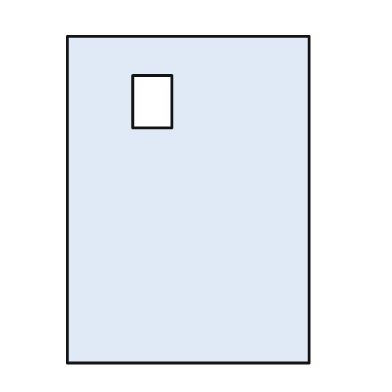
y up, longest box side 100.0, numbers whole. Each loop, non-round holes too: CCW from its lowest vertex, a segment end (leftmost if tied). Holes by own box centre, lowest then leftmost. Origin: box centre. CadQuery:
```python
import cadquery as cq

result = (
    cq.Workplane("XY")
    .moveTo(-37.0, -50.0)
    .lineTo(37.0, -50.0)
    .lineTo(37.0, 50.0)
    .lineTo(-37.0, 50.0)
    .close()
    .moveTo(-17.0, 22.0)
    .lineTo(-5.0, 22.0)
    .lineTo(-5.0, 38.0)
    .lineTo(-17.0, 38.0)
    .close()
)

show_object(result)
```